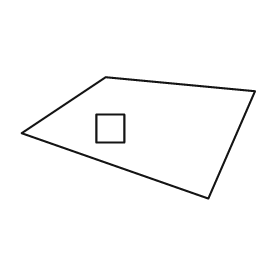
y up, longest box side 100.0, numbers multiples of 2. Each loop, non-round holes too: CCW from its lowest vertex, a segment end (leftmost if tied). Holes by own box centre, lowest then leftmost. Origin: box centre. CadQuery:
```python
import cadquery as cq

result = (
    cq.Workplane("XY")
    .moveTo(30.0, -26.0)
    .lineTo(50.0, 20.0)
    .lineTo(-14.0, 26.0)
    .lineTo(-50.0, 2.0)
    .close()
    .moveTo(-18.0, -2.0)
    .lineTo(-6.0, -2.0)
    .lineTo(-6.0, 10.0)
    .lineTo(-18.0, 10.0)
    .close()
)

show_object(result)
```